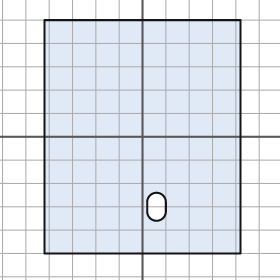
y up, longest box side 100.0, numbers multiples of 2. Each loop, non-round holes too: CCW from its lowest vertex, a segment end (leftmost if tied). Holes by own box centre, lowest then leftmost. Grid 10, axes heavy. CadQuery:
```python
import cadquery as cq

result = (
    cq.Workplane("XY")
    .moveTo(-42.0, -50.0)
    .lineTo(42.0, -50.0)
    .lineTo(42.0, 50.0)
    .lineTo(-42.0, 50.0)
    .close()
    .moveTo(2.0, -32.0)
    .threePointArc((6.0, -36.0), (10.0, -32.0))
    .lineTo(10.0, -28.0)
    .threePointArc((6.0, -24.0), (2.0, -28.0))
    .close()
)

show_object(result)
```